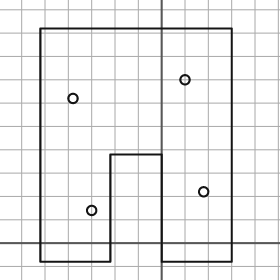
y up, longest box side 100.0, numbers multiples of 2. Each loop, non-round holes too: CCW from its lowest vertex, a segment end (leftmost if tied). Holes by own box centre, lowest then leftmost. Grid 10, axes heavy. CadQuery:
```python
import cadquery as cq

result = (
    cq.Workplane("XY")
    .moveTo(-52.0, -8.0)
    .lineTo(-22.0, -8.0)
    .lineTo(-22.0, 38.0)
    .lineTo(0.0, 38.0)
    .lineTo(0.0, -8.0)
    .lineTo(30.0, -8.0)
    .lineTo(30.0, 92.0)
    .lineTo(-52.0, 92.0)
    .close()
    .moveTo(-30.0, 14.0)
    .circle(2.0)
    .moveTo(18.0, 22.0)
    .circle(2.0)
    .moveTo(-38.0, 62.0)
    .circle(2.0)
    .moveTo(10.0, 70.0)
    .circle(2.0)
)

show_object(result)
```